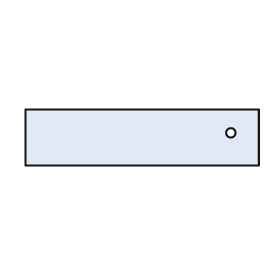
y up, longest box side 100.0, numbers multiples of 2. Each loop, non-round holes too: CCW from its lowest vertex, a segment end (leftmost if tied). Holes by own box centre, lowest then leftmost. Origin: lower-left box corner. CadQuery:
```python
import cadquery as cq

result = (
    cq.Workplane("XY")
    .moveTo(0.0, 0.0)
    .lineTo(100.0, 0.0)
    .lineTo(100.0, 24.0)
    .lineTo(0.0, 24.0)
    .close()
    .moveTo(88.0, 14.0)
    .circle(2.0)
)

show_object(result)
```